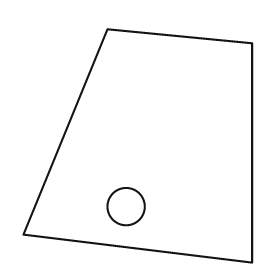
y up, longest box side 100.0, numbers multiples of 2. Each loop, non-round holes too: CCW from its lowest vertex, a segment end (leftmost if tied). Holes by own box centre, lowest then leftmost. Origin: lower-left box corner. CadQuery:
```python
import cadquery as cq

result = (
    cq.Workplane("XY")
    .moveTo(98.0, 0.0)
    .lineTo(98.0, 94.0)
    .lineTo(36.0, 100.0)
    .lineTo(0.0, 12.0)
    .close()
    .moveTo(44.0, 24.0)
    .circle(8.0)
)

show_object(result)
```